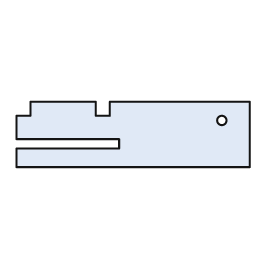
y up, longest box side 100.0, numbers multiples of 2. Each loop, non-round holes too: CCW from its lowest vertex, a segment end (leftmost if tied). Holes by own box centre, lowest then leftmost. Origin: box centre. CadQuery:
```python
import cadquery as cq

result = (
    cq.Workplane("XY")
    .moveTo(-50.0, -14.0)
    .lineTo(50.0, -14.0)
    .lineTo(50.0, 14.0)
    .lineTo(-10.0, 14.0)
    .lineTo(-10.0, 8.0)
    .lineTo(-16.0, 8.0)
    .lineTo(-16.0, 14.0)
    .lineTo(-44.0, 14.0)
    .lineTo(-44.0, 8.0)
    .lineTo(-50.0, 8.0)
    .lineTo(-50.0, -2.0)
    .lineTo(-6.0, -2.0)
    .lineTo(-6.0, -6.0)
    .lineTo(-50.0, -6.0)
    .close()
    .moveTo(38.0, 6.0)
    .circle(2.0)
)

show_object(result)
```